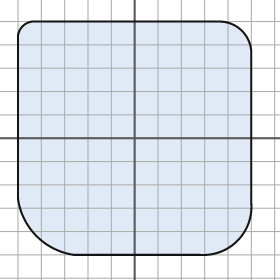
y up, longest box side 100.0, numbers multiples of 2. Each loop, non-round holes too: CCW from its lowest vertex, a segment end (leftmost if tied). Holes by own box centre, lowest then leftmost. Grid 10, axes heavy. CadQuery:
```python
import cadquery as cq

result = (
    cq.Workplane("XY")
    .moveTo(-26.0, -50.0)
    .lineTo(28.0, -50.0)
    .threePointArc((44.0, -44.0), (50.0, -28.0))
    .lineTo(50.0, 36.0)
    .threePointArc((46.0, 46.0), (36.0, 50.0))
    .lineTo(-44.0, 50.0)
    .threePointArc((-48.0, 48.0), (-50.0, 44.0))
    .lineTo(-50.0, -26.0)
    .threePointArc((-42.0, -42.0), (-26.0, -50.0))
    .close()
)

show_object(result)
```